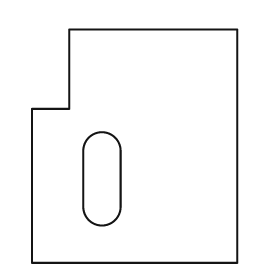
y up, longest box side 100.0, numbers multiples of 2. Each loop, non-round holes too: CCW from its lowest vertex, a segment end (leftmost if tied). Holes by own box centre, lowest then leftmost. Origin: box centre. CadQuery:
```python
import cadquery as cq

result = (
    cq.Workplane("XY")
    .moveTo(-44.0, -50.0)
    .lineTo(44.0, -50.0)
    .lineTo(44.0, 50.0)
    .lineTo(-28.0, 50.0)
    .lineTo(-28.0, 16.0)
    .lineTo(-44.0, 16.0)
    .close()
    .moveTo(-22.0, -26.0)
    .threePointArc((-14.0, -34.0), (-6.0, -26.0))
    .lineTo(-6.0, -2.0)
    .threePointArc((-14.0, 6.0), (-22.0, -2.0))
    .close()
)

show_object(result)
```